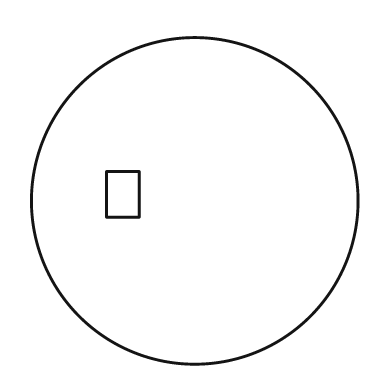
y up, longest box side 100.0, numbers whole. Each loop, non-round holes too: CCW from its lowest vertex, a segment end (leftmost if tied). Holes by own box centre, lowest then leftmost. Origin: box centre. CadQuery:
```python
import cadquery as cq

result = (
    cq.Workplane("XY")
    .moveTo(0.0, 0.0)
    .circle(50.0)
    .moveTo(-27.0, -5.0)
    .lineTo(-17.0, -5.0)
    .lineTo(-17.0, 9.0)
    .lineTo(-27.0, 9.0)
    .close()
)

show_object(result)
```